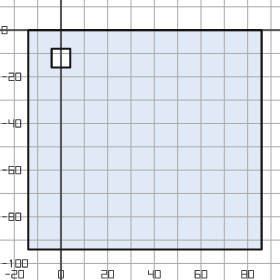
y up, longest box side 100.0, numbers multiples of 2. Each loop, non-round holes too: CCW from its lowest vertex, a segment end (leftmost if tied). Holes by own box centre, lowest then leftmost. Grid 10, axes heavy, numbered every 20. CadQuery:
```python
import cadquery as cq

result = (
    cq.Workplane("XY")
    .moveTo(-14.0, -94.0)
    .lineTo(86.0, -94.0)
    .lineTo(86.0, 0.0)
    .lineTo(-14.0, 0.0)
    .close()
    .moveTo(-4.0, -16.0)
    .lineTo(4.0, -16.0)
    .lineTo(4.0, -8.0)
    .lineTo(-4.0, -8.0)
    .close()
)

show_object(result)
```